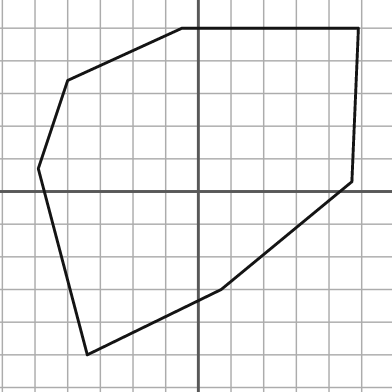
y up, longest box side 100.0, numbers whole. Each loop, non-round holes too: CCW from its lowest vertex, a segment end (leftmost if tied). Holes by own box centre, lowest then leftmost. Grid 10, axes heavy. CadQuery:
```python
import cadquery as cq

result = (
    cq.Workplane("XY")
    .moveTo(-34.0, -50.0)
    .lineTo(7.0, -30.0)
    .lineTo(47.0, 3.0)
    .lineTo(49.0, 50.0)
    .lineTo(-5.0, 50.0)
    .lineTo(-40.0, 34.0)
    .lineTo(-49.0, 7.0)
    .close()
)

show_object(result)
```